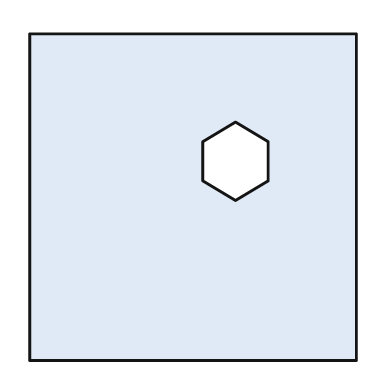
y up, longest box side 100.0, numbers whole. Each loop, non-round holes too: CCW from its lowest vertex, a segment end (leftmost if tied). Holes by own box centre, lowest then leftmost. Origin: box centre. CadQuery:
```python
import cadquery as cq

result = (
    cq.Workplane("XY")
    .moveTo(-50.0, -50.0)
    .lineTo(50.0, -50.0)
    .lineTo(50.0, 50.0)
    .lineTo(-50.0, 50.0)
    .close()
    .moveTo(13.0, -1.0)
    .lineTo(23.0, 5.0)
    .lineTo(23.0, 17.0)
    .lineTo(13.0, 23.0)
    .lineTo(3.0, 17.0)
    .lineTo(3.0, 5.0)
    .close()
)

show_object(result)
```